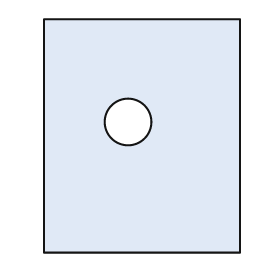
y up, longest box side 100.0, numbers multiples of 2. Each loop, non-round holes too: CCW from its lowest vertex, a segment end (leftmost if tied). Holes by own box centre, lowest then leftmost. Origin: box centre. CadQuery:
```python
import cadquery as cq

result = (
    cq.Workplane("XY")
    .moveTo(-42.0, -50.0)
    .lineTo(42.0, -50.0)
    .lineTo(42.0, 50.0)
    .lineTo(-42.0, 50.0)
    .close()
    .moveTo(-6.0, 6.0)
    .circle(10.0)
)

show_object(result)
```